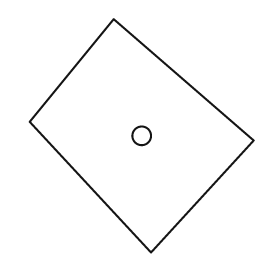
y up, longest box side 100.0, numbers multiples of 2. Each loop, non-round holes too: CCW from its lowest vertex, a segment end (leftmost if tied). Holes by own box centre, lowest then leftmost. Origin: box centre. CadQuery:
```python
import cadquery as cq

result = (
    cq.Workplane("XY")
    .moveTo(4.0, -50.0)
    .lineTo(48.0, -2.0)
    .lineTo(-12.0, 50.0)
    .lineTo(-48.0, 6.0)
    .close()
    .moveTo(0.0, 0.0)
    .circle(4.0)
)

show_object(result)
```